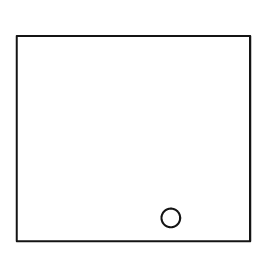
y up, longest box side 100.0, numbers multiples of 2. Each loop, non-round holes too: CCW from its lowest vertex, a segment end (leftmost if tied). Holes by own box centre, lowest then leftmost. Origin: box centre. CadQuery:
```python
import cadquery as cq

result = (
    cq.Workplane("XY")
    .moveTo(-50.0, -44.0)
    .lineTo(50.0, -44.0)
    .lineTo(50.0, 44.0)
    .lineTo(-50.0, 44.0)
    .close()
    .moveTo(16.0, -34.0)
    .circle(4.0)
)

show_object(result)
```